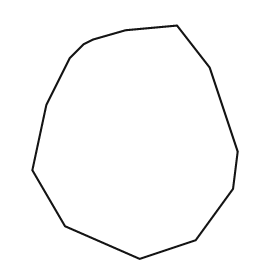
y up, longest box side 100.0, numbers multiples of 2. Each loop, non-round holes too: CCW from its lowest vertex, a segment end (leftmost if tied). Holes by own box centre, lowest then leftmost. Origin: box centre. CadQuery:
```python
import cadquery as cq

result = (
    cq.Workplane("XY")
    .moveTo(2.0, -50.0)
    .lineTo(26.0, -42.0)
    .lineTo(42.0, -20.0)
    .lineTo(44.0, -4.0)
    .lineTo(32.0, 32.0)
    .lineTo(18.0, 50.0)
    .lineTo(-4.0, 48.0)
    .lineTo(-18.0, 44.0)
    .lineTo(-22.0, 42.0)
    .lineTo(-28.0, 36.0)
    .lineTo(-38.0, 16.0)
    .lineTo(-44.0, -12.0)
    .lineTo(-30.0, -36.0)
    .close()
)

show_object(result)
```